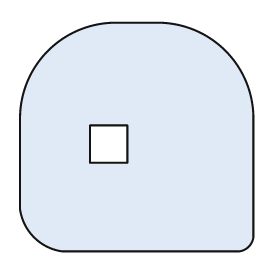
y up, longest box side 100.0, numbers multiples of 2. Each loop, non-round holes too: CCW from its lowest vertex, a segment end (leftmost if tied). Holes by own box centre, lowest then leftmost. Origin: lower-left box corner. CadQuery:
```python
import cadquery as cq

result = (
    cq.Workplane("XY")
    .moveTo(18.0, 0.0)
    .lineTo(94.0, 0.0)
    .threePointArc((98.0, 2.0), (100.0, 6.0))
    .lineTo(100.0, 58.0)
    .threePointArc((88.0, 86.0), (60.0, 98.0))
    .lineTo(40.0, 98.0)
    .threePointArc((12.0, 86.0), (0.0, 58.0))
    .lineTo(0.0, 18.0)
    .threePointArc((6.0, 6.0), (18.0, 0.0))
    .close()
    .moveTo(30.0, 38.0)
    .lineTo(46.0, 38.0)
    .lineTo(46.0, 54.0)
    .lineTo(30.0, 54.0)
    .close()
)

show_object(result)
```